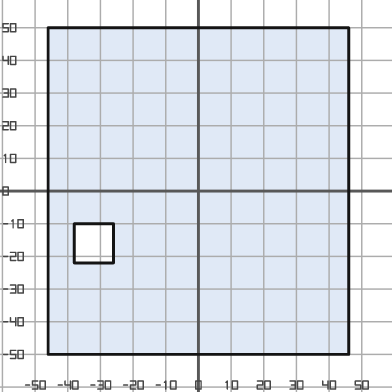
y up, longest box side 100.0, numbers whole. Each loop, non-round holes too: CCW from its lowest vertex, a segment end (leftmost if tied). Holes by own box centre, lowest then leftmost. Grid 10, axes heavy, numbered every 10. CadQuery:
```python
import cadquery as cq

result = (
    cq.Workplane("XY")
    .moveTo(-46.0, -50.0)
    .lineTo(46.0, -50.0)
    .lineTo(46.0, 50.0)
    .lineTo(-46.0, 50.0)
    .close()
    .moveTo(-38.0, -22.0)
    .lineTo(-26.0, -22.0)
    .lineTo(-26.0, -10.0)
    .lineTo(-38.0, -10.0)
    .close()
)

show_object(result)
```